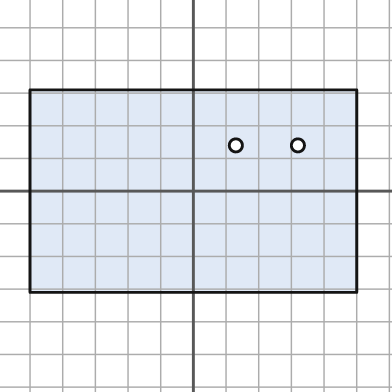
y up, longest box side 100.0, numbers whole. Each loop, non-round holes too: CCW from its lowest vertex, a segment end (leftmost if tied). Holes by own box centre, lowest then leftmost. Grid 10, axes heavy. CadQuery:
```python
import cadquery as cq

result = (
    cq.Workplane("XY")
    .moveTo(-50.0, -31.0)
    .lineTo(50.0, -31.0)
    .lineTo(50.0, 31.0)
    .lineTo(-50.0, 31.0)
    .close()
    .moveTo(13.0, 14.0)
    .circle(2.0)
    .moveTo(32.0, 14.0)
    .circle(2.0)
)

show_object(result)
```